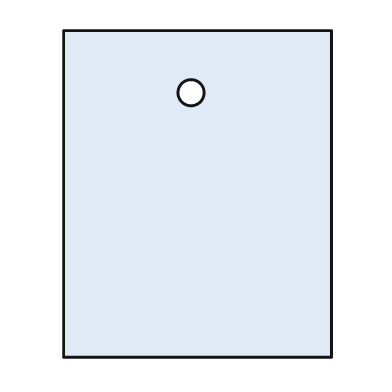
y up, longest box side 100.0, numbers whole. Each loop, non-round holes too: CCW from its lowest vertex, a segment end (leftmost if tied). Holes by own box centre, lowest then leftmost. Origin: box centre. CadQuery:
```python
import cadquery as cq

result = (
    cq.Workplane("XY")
    .moveTo(-41.0, -50.0)
    .lineTo(41.0, -50.0)
    .lineTo(41.0, 50.0)
    .lineTo(-41.0, 50.0)
    .close()
    .moveTo(-2.0, 31.0)
    .circle(4.0)
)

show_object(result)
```